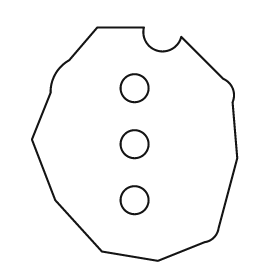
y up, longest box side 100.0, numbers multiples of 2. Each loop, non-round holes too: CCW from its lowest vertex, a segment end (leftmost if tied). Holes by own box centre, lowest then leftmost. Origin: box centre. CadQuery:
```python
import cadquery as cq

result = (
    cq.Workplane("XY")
    .moveTo(10.0, -50.0)
    .lineTo(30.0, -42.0)
    .threePointArc((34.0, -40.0), (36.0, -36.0))
    .lineTo(44.0, -6.0)
    .lineTo(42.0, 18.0)
    .threePointArc((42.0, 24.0), (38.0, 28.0))
    .lineTo(20.0, 46.0)
    .threePointArc((10.0, 40.0), (4.0, 50.0))
    .lineTo(-16.0, 50.0)
    .lineTo(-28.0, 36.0)
    .threePointArc((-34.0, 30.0), (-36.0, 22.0))
    .lineTo(-44.0, 2.0)
    .lineTo(-34.0, -24.0)
    .lineTo(-14.0, -46.0)
    .close()
    .moveTo(0.0, -24.0)
    .circle(6.0)
    .moveTo(0.0, 0.0)
    .circle(6.0)
    .moveTo(0.0, 24.0)
    .circle(6.0)
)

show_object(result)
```